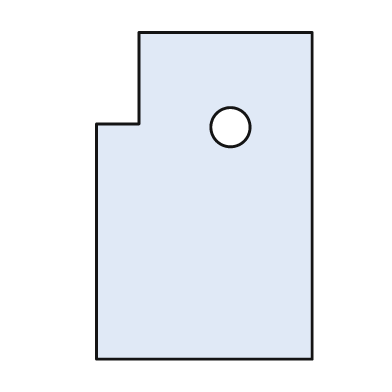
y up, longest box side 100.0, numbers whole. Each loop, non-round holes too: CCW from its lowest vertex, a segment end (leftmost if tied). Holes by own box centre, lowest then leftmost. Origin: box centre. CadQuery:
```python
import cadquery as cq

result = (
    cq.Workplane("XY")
    .moveTo(-33.0, -50.0)
    .lineTo(33.0, -50.0)
    .lineTo(33.0, 50.0)
    .lineTo(-20.0, 50.0)
    .lineTo(-20.0, 22.0)
    .lineTo(-33.0, 22.0)
    .close()
    .moveTo(8.0, 21.0)
    .circle(6.0)
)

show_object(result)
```